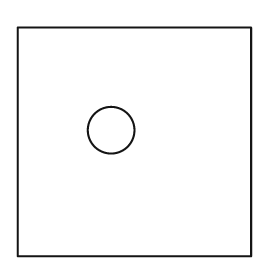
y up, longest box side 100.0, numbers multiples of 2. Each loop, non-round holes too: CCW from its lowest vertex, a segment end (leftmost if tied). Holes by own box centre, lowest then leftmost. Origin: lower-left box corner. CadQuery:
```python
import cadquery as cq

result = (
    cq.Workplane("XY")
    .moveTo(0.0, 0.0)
    .lineTo(100.0, 0.0)
    .lineTo(100.0, 98.0)
    .lineTo(0.0, 98.0)
    .close()
    .moveTo(40.0, 54.0)
    .circle(10.0)
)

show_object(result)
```